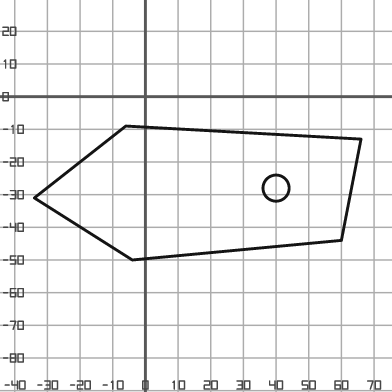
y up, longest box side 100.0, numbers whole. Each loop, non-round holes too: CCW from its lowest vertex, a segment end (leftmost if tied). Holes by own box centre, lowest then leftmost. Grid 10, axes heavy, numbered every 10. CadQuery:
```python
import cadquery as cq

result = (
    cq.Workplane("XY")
    .moveTo(-4.0, -50.0)
    .lineTo(60.0, -44.0)
    .lineTo(66.0, -13.0)
    .lineTo(-6.0, -9.0)
    .lineTo(-34.0, -31.0)
    .close()
    .moveTo(40.0, -28.0)
    .circle(4.0)
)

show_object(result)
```